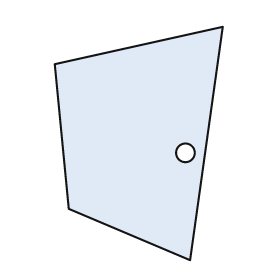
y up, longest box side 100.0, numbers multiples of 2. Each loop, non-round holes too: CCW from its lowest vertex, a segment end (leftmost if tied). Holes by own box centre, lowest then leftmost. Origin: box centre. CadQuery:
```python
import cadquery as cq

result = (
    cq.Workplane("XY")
    .moveTo(22.0, -50.0)
    .lineTo(36.0, 50.0)
    .lineTo(-36.0, 34.0)
    .lineTo(-30.0, -28.0)
    .close()
    .moveTo(20.0, -4.0)
    .circle(4.0)
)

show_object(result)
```